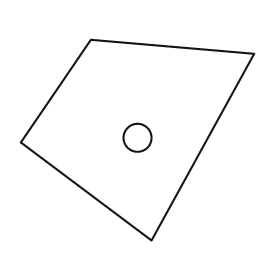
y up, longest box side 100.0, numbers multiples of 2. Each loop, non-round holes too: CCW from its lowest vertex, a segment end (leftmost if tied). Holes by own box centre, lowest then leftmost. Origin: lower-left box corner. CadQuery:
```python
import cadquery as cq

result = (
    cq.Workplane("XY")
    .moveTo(56.0, 0.0)
    .lineTo(100.0, 80.0)
    .lineTo(30.0, 86.0)
    .lineTo(0.0, 42.0)
    .close()
    .moveTo(50.0, 44.0)
    .circle(6.0)
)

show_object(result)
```